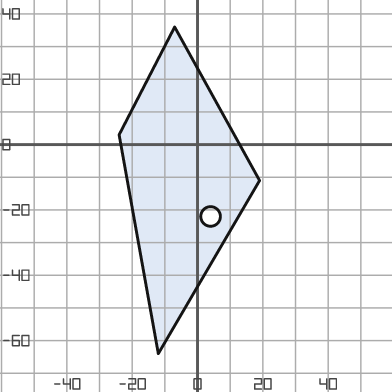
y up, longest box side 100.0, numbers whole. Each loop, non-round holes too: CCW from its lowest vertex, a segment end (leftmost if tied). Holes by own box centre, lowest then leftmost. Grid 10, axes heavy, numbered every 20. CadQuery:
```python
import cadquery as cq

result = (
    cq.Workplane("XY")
    .moveTo(-12.0, -64.0)
    .lineTo(19.0, -11.0)
    .lineTo(-7.0, 36.0)
    .lineTo(-24.0, 3.0)
    .close()
    .moveTo(4.0, -22.0)
    .circle(3.0)
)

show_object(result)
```